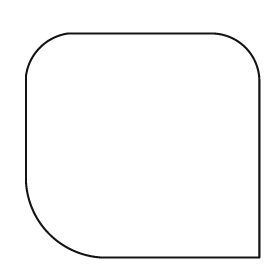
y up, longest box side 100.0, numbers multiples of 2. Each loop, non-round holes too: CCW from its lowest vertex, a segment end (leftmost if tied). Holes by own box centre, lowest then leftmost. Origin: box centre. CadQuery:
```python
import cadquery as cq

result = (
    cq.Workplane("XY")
    .moveTo(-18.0, -48.0)
    .lineTo(50.0, -48.0)
    .lineTo(50.0, 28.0)
    .threePointArc((44.0, 42.0), (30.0, 48.0))
    .lineTo(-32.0, 48.0)
    .threePointArc((-44.0, 42.0), (-50.0, 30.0))
    .lineTo(-50.0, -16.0)
    .threePointArc((-40.0, -38.0), (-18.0, -48.0))
    .close()
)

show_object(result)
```